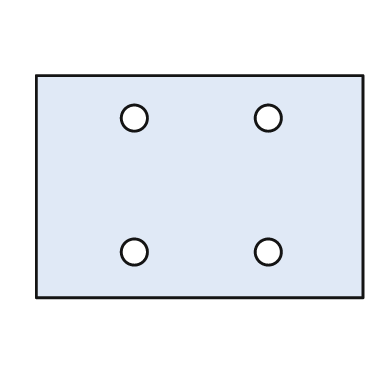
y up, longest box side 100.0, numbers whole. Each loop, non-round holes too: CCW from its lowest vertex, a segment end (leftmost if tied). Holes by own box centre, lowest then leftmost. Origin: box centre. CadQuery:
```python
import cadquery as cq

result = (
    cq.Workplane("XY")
    .moveTo(-50.0, -34.0)
    .lineTo(50.0, -34.0)
    .lineTo(50.0, 34.0)
    .lineTo(-50.0, 34.0)
    .close()
    .moveTo(-20.0, -20.0)
    .circle(4.0)
    .moveTo(21.0, -20.0)
    .circle(4.0)
    .moveTo(-20.0, 21.0)
    .circle(4.0)
    .moveTo(21.0, 21.0)
    .circle(4.0)
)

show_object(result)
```